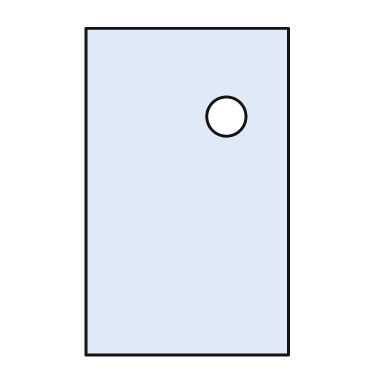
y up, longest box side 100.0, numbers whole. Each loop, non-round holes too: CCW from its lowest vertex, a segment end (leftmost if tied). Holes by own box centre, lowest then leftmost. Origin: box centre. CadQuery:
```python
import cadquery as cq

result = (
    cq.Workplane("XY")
    .moveTo(-31.0, -50.0)
    .lineTo(31.0, -50.0)
    .lineTo(31.0, 50.0)
    .lineTo(-31.0, 50.0)
    .close()
    .moveTo(12.0, 23.0)
    .circle(6.0)
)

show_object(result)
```